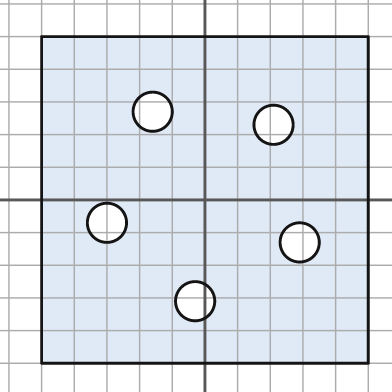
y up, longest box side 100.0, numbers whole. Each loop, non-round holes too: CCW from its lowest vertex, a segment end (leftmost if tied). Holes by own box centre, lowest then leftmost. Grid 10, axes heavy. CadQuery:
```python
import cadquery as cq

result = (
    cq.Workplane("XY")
    .moveTo(-50.0, -50.0)
    .lineTo(50.0, -50.0)
    .lineTo(50.0, 50.0)
    .lineTo(-50.0, 50.0)
    .close()
    .moveTo(-3.0, -31.0)
    .circle(6.0)
    .moveTo(29.0, -13.0)
    .circle(6.0)
    .moveTo(-30.0, -7.0)
    .circle(6.0)
    .moveTo(21.0, 23.0)
    .circle(6.0)
    .moveTo(-16.0, 27.0)
    .circle(6.0)
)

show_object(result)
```